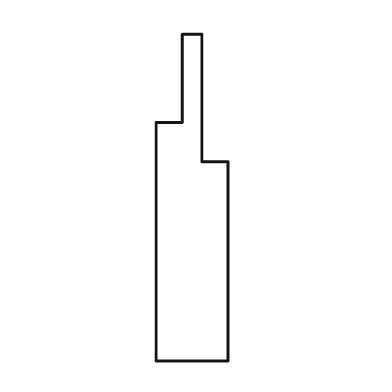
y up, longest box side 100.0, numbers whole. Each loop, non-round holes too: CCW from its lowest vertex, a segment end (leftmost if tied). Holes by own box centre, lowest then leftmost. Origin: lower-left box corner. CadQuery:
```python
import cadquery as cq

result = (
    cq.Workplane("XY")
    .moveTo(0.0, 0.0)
    .lineTo(22.0, 0.0)
    .lineTo(22.0, 61.0)
    .lineTo(14.0, 61.0)
    .lineTo(14.0, 100.0)
    .lineTo(8.0, 100.0)
    .lineTo(8.0, 73.0)
    .lineTo(0.0, 73.0)
    .close()
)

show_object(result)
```